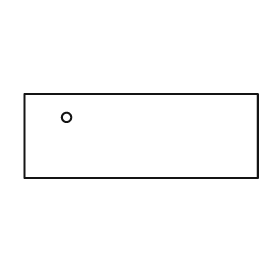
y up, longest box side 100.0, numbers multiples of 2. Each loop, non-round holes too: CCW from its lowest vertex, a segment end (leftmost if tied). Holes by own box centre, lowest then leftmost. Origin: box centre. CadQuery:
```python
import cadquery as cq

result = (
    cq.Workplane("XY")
    .moveTo(-50.0, -18.0)
    .lineTo(50.0, -18.0)
    .lineTo(50.0, 18.0)
    .lineTo(-50.0, 18.0)
    .close()
    .moveTo(-32.0, 8.0)
    .circle(2.0)
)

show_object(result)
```